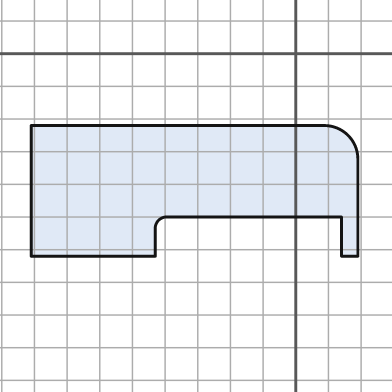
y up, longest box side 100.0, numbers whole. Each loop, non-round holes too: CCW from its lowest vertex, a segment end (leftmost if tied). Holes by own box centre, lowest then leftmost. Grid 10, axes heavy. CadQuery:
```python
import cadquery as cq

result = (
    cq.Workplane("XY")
    .moveTo(-81.0, -62.0)
    .lineTo(-43.0, -62.0)
    .lineTo(-43.0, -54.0)
    .threePointArc((-42.0, -51.0), (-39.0, -50.0))
    .lineTo(14.0, -50.0)
    .lineTo(14.0, -62.0)
    .lineTo(19.0, -62.0)
    .lineTo(19.0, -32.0)
    .threePointArc((16.0, -25.0), (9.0, -22.0))
    .lineTo(-81.0, -22.0)
    .close()
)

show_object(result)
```